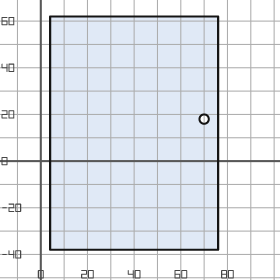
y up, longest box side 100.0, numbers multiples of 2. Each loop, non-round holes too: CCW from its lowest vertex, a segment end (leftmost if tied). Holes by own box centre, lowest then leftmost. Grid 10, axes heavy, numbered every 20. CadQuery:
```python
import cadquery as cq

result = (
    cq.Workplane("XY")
    .moveTo(4.0, -38.0)
    .lineTo(76.0, -38.0)
    .lineTo(76.0, 62.0)
    .lineTo(4.0, 62.0)
    .close()
    .moveTo(70.0, 18.0)
    .circle(2.0)
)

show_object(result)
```